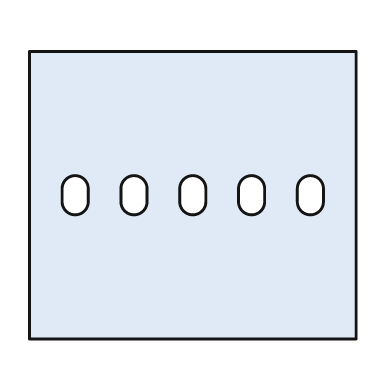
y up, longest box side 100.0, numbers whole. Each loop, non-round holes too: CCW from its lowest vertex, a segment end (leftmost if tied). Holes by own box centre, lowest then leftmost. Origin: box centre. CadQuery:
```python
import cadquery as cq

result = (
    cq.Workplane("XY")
    .moveTo(-50.0, -44.0)
    .lineTo(50.0, -44.0)
    .lineTo(50.0, 44.0)
    .lineTo(-50.0, 44.0)
    .close()
    .moveTo(-40.0, -2.0)
    .threePointArc((-36.0, -6.0), (-32.0, -2.0))
    .lineTo(-32.0, 2.0)
    .threePointArc((-36.0, 6.0), (-40.0, 2.0))
    .close()
    .moveTo(-22.0, -2.0)
    .threePointArc((-18.0, -6.0), (-14.0, -2.0))
    .lineTo(-14.0, 2.0)
    .threePointArc((-18.0, 6.0), (-22.0, 2.0))
    .close()
    .moveTo(-4.0, -2.0)
    .threePointArc((0.0, -6.0), (4.0, -2.0))
    .lineTo(4.0, 2.0)
    .threePointArc((0.0, 6.0), (-4.0, 2.0))
    .close()
    .moveTo(14.0, -2.0)
    .threePointArc((18.0, -6.0), (22.0, -2.0))
    .lineTo(22.0, 2.0)
    .threePointArc((18.0, 6.0), (14.0, 2.0))
    .close()
    .moveTo(32.0, -2.0)
    .threePointArc((36.0, -6.0), (40.0, -2.0))
    .lineTo(40.0, 2.0)
    .threePointArc((36.0, 6.0), (32.0, 2.0))
    .close()
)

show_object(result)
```